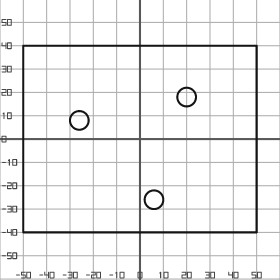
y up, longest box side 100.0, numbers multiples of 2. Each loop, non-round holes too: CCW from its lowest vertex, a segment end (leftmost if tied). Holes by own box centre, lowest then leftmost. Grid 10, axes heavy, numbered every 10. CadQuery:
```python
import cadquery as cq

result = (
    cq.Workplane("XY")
    .moveTo(-50.0, -40.0)
    .lineTo(50.0, -40.0)
    .lineTo(50.0, 40.0)
    .lineTo(-50.0, 40.0)
    .close()
    .moveTo(6.0, -26.0)
    .circle(4.0)
    .moveTo(-26.0, 8.0)
    .circle(4.0)
    .moveTo(20.0, 18.0)
    .circle(4.0)
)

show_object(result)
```